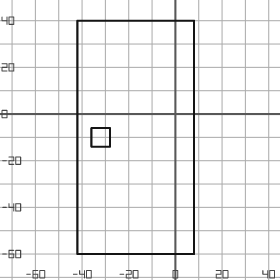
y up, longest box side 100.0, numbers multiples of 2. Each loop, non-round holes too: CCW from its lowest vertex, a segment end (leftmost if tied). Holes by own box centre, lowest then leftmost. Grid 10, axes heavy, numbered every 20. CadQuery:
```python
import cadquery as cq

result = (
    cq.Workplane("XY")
    .moveTo(-42.0, -60.0)
    .lineTo(8.0, -60.0)
    .lineTo(8.0, 40.0)
    .lineTo(-42.0, 40.0)
    .close()
    .moveTo(-36.0, -14.0)
    .lineTo(-28.0, -14.0)
    .lineTo(-28.0, -6.0)
    .lineTo(-36.0, -6.0)
    .close()
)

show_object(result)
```